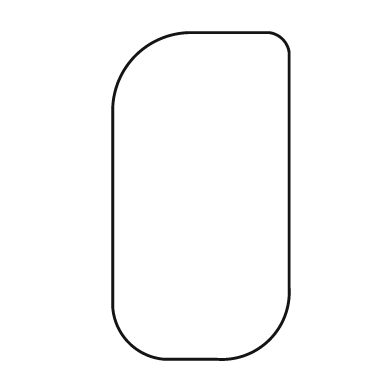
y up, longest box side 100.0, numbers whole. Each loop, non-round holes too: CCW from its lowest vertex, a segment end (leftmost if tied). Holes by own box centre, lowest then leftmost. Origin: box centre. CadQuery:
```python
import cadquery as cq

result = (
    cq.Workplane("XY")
    .moveTo(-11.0, -50.0)
    .lineTo(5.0, -50.0)
    .threePointArc((21.0, -44.0), (27.0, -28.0))
    .lineTo(27.0, 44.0)
    .threePointArc((25.0, 48.0), (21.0, 50.0))
    .lineTo(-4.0, 50.0)
    .threePointArc((-20.0, 43.0), (-27.0, 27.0))
    .lineTo(-27.0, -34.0)
    .threePointArc((-22.0, -45.0), (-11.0, -50.0))
    .close()
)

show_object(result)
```